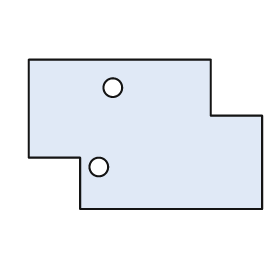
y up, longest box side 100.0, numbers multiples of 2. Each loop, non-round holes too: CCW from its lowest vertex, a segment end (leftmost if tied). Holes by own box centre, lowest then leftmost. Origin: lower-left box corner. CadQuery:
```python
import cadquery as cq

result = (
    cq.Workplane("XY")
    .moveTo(22.0, 0.0)
    .lineTo(100.0, 0.0)
    .lineTo(100.0, 40.0)
    .lineTo(78.0, 40.0)
    .lineTo(78.0, 64.0)
    .lineTo(0.0, 64.0)
    .lineTo(0.0, 22.0)
    .lineTo(22.0, 22.0)
    .close()
    .moveTo(30.0, 18.0)
    .circle(4.0)
    .moveTo(36.0, 52.0)
    .circle(4.0)
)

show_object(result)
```